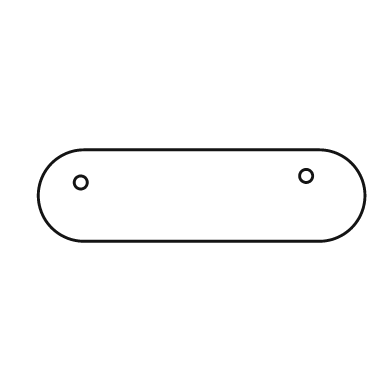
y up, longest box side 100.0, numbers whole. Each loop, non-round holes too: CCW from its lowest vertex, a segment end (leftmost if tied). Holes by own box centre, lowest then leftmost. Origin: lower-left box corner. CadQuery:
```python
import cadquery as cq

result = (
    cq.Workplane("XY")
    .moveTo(14.0, 0.0)
    .lineTo(86.0, 0.0)
    .threePointArc((100.0, 14.0), (86.0, 28.0))
    .lineTo(14.0, 28.0)
    .threePointArc((0.0, 14.0), (14.0, 0.0))
    .close()
    .moveTo(13.0, 18.0)
    .circle(2.0)
    .moveTo(82.0, 20.0)
    .circle(2.0)
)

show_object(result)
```